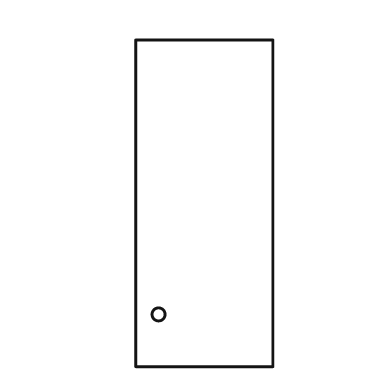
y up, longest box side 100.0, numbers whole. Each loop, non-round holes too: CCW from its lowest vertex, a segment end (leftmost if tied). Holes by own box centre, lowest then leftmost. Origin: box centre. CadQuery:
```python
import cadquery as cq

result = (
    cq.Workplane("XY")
    .moveTo(-21.0, -50.0)
    .lineTo(21.0, -50.0)
    .lineTo(21.0, 50.0)
    .lineTo(-21.0, 50.0)
    .close()
    .moveTo(-14.0, -34.0)
    .circle(2.0)
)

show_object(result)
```